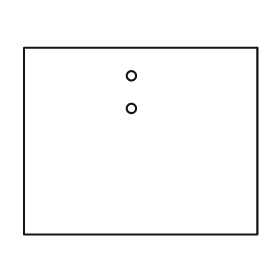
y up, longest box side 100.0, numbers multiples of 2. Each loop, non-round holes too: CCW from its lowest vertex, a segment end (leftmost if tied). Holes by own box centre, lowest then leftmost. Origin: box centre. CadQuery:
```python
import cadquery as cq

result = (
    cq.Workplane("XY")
    .moveTo(-50.0, -40.0)
    .lineTo(50.0, -40.0)
    .lineTo(50.0, 40.0)
    .lineTo(-50.0, 40.0)
    .close()
    .moveTo(-4.0, 14.0)
    .circle(2.0)
    .moveTo(-4.0, 28.0)
    .circle(2.0)
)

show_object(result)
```